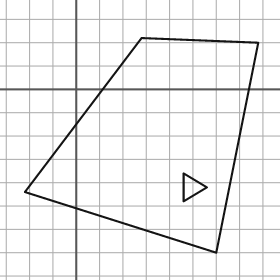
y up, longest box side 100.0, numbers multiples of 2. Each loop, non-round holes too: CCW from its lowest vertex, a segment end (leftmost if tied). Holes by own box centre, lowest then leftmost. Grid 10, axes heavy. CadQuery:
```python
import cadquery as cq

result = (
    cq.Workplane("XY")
    .moveTo(60.0, -70.0)
    .lineTo(78.0, 20.0)
    .lineTo(28.0, 22.0)
    .lineTo(-22.0, -44.0)
    .close()
    .moveTo(46.0, -48.0)
    .lineTo(56.0, -42.0)
    .lineTo(46.0, -36.0)
    .close()
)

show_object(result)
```